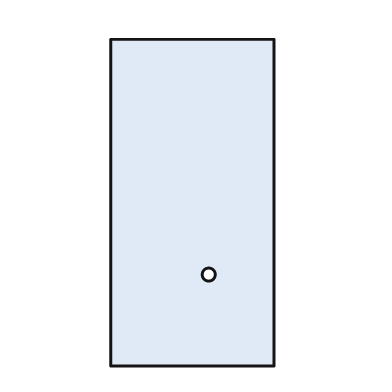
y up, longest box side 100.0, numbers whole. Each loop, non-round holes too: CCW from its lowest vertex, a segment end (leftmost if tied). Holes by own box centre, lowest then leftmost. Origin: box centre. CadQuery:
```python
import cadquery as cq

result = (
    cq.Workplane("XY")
    .moveTo(-25.0, -50.0)
    .lineTo(25.0, -50.0)
    .lineTo(25.0, 50.0)
    .lineTo(-25.0, 50.0)
    .close()
    .moveTo(5.0, -22.0)
    .circle(2.0)
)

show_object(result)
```